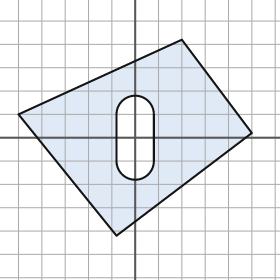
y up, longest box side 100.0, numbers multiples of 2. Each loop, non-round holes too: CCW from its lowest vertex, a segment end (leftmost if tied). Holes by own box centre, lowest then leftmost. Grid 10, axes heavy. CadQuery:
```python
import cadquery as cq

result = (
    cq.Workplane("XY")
    .moveTo(-8.0, -42.0)
    .lineTo(50.0, 2.0)
    .lineTo(20.0, 42.0)
    .lineTo(-50.0, 10.0)
    .close()
    .moveTo(-8.0, -10.0)
    .threePointArc((0.0, -18.0), (8.0, -10.0))
    .lineTo(8.0, 10.0)
    .threePointArc((0.0, 18.0), (-8.0, 10.0))
    .close()
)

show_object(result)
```